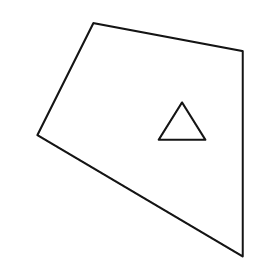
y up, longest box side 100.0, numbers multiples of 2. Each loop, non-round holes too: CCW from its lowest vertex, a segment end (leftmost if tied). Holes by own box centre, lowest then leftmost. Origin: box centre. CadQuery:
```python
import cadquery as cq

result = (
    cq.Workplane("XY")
    .moveTo(44.0, -50.0)
    .lineTo(44.0, 38.0)
    .lineTo(-20.0, 50.0)
    .lineTo(-44.0, 2.0)
    .close()
    .moveTo(8.0, 0.0)
    .lineTo(28.0, 0.0)
    .lineTo(18.0, 16.0)
    .close()
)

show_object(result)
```